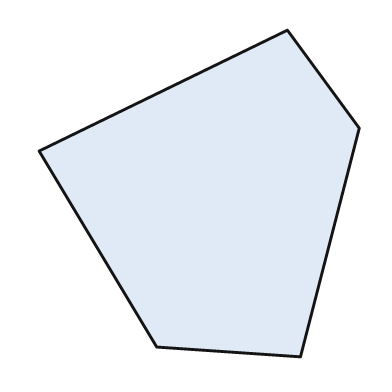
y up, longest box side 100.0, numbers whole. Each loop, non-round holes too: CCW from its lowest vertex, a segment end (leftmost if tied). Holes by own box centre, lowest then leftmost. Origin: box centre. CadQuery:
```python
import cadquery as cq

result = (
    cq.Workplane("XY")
    .moveTo(31.0, -50.0)
    .lineTo(49.0, 20.0)
    .lineTo(27.0, 50.0)
    .lineTo(-49.0, 13.0)
    .lineTo(-13.0, -47.0)
    .close()
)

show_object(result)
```